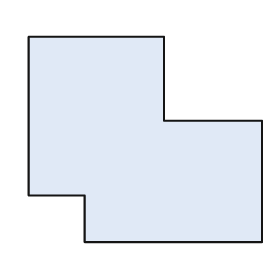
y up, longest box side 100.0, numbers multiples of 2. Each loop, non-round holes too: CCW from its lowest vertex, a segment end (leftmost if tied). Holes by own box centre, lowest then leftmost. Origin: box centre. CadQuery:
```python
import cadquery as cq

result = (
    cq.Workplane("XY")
    .moveTo(-26.0, -44.0)
    .lineTo(50.0, -44.0)
    .lineTo(50.0, 8.0)
    .lineTo(8.0, 8.0)
    .lineTo(8.0, 44.0)
    .lineTo(-50.0, 44.0)
    .lineTo(-50.0, -24.0)
    .lineTo(-26.0, -24.0)
    .close()
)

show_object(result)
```